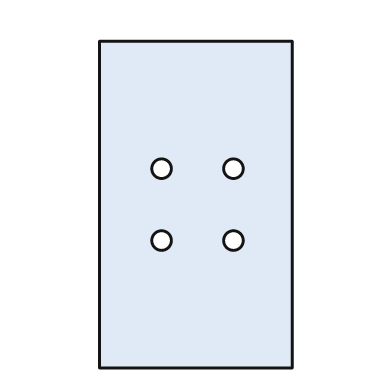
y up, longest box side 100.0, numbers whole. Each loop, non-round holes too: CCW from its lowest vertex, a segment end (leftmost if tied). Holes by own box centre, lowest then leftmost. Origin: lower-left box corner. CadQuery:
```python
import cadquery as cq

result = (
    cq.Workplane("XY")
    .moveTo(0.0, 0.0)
    .lineTo(59.0, 0.0)
    .lineTo(59.0, 100.0)
    .lineTo(0.0, 100.0)
    .close()
    .moveTo(19.0, 39.0)
    .circle(3.0)
    .moveTo(41.0, 39.0)
    .circle(3.0)
    .moveTo(19.0, 61.0)
    .circle(3.0)
    .moveTo(41.0, 61.0)
    .circle(3.0)
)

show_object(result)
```